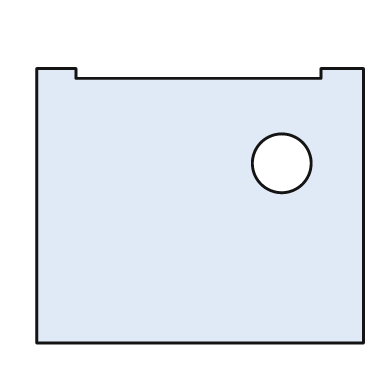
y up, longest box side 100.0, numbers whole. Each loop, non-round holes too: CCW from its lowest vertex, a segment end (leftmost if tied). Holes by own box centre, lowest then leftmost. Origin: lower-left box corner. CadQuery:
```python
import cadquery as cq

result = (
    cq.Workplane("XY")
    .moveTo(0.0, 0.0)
    .lineTo(100.0, 0.0)
    .lineTo(100.0, 84.0)
    .lineTo(87.0, 84.0)
    .lineTo(87.0, 81.0)
    .lineTo(12.0, 81.0)
    .lineTo(12.0, 84.0)
    .lineTo(0.0, 84.0)
    .close()
    .moveTo(75.0, 55.0)
    .circle(9.0)
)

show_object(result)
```